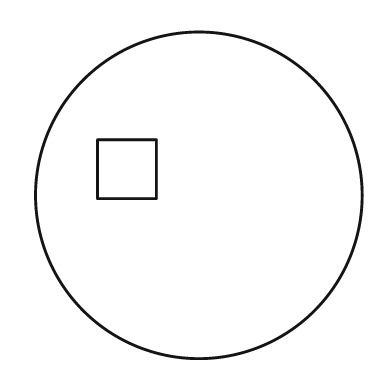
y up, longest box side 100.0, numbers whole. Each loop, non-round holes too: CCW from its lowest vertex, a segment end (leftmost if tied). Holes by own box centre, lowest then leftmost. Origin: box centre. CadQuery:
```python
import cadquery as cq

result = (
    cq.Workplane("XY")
    .moveTo(0.0, 0.0)
    .circle(50.0)
    .moveTo(-31.0, -1.0)
    .lineTo(-13.0, -1.0)
    .lineTo(-13.0, 17.0)
    .lineTo(-31.0, 17.0)
    .close()
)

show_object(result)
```